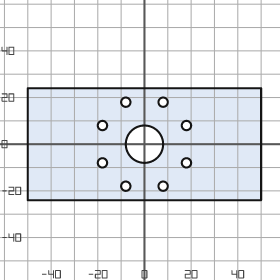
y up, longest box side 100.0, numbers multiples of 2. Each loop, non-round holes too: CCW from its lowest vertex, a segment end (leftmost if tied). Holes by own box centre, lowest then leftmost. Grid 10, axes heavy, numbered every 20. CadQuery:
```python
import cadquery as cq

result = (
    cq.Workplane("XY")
    .moveTo(-50.0, -24.0)
    .lineTo(50.0, -24.0)
    .lineTo(50.0, 24.0)
    .lineTo(-50.0, 24.0)
    .close()
    .moveTo(-8.0, -18.0)
    .circle(2.0)
    .moveTo(8.0, -18.0)
    .circle(2.0)
    .moveTo(-18.0, -8.0)
    .circle(2.0)
    .moveTo(18.0, -8.0)
    .circle(2.0)
    .moveTo(0.0, 0.0)
    .circle(8.0)
    .moveTo(-18.0, 8.0)
    .circle(2.0)
    .moveTo(18.0, 8.0)
    .circle(2.0)
    .moveTo(-8.0, 18.0)
    .circle(2.0)
    .moveTo(8.0, 18.0)
    .circle(2.0)
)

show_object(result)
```